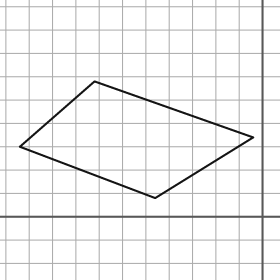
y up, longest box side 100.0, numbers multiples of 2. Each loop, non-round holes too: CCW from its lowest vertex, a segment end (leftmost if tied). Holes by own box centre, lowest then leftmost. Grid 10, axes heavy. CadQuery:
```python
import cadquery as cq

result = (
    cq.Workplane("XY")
    .moveTo(-46.0, 8.0)
    .lineTo(-4.0, 34.0)
    .lineTo(-72.0, 58.0)
    .lineTo(-104.0, 30.0)
    .close()
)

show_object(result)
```